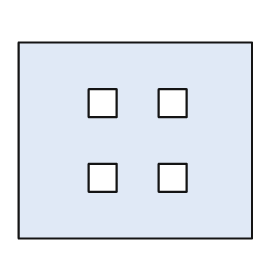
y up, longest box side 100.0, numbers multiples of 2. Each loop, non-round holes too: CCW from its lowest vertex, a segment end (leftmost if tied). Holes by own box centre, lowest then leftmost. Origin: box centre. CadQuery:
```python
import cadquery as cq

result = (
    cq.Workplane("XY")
    .moveTo(-50.0, -42.0)
    .lineTo(50.0, -42.0)
    .lineTo(50.0, 42.0)
    .lineTo(-50.0, 42.0)
    .close()
    .moveTo(-20.0, -22.0)
    .lineTo(-8.0, -22.0)
    .lineTo(-8.0, -10.0)
    .lineTo(-20.0, -10.0)
    .close()
    .moveTo(10.0, -22.0)
    .lineTo(22.0, -22.0)
    .lineTo(22.0, -10.0)
    .lineTo(10.0, -10.0)
    .close()
    .moveTo(-20.0, 10.0)
    .lineTo(-8.0, 10.0)
    .lineTo(-8.0, 22.0)
    .lineTo(-20.0, 22.0)
    .close()
    .moveTo(10.0, 10.0)
    .lineTo(22.0, 10.0)
    .lineTo(22.0, 22.0)
    .lineTo(10.0, 22.0)
    .close()
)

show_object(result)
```